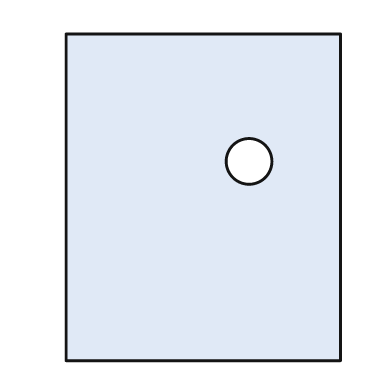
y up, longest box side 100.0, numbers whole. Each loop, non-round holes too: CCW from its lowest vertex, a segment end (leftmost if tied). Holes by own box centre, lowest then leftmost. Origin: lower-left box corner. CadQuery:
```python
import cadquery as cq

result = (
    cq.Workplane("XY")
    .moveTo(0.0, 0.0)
    .lineTo(84.0, 0.0)
    .lineTo(84.0, 100.0)
    .lineTo(0.0, 100.0)
    .close()
    .moveTo(56.0, 61.0)
    .circle(7.0)
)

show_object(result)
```